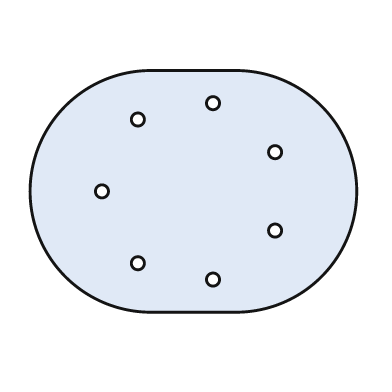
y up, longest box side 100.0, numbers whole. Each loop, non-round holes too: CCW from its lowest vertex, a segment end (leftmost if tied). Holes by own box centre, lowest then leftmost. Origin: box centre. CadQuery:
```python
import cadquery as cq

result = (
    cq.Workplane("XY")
    .moveTo(-13.0, -37.0)
    .lineTo(13.0, -37.0)
    .threePointArc((50.0, 0.0), (13.0, 37.0))
    .lineTo(-13.0, 37.0)
    .threePointArc((-50.0, 0.0), (-13.0, -37.0))
    .close()
    .moveTo(6.0, -27.0)
    .circle(2.0)
    .moveTo(-17.0, -22.0)
    .circle(2.0)
    .moveTo(25.0, -12.0)
    .circle(2.0)
    .moveTo(-28.0, 0.0)
    .circle(2.0)
    .moveTo(25.0, 12.0)
    .circle(2.0)
    .moveTo(-17.0, 22.0)
    .circle(2.0)
    .moveTo(6.0, 27.0)
    .circle(2.0)
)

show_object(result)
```